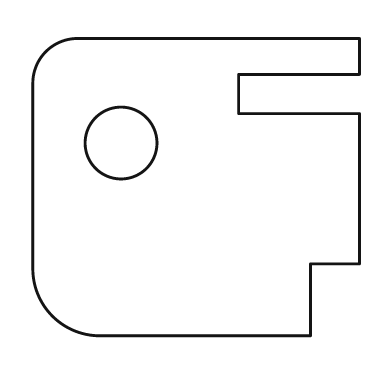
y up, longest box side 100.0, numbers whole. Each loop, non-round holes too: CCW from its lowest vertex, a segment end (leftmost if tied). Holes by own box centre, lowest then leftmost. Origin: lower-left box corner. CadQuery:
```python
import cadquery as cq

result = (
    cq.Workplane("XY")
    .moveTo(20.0, 0.0)
    .lineTo(85.0, 0.0)
    .lineTo(85.0, 22.0)
    .lineTo(100.0, 22.0)
    .lineTo(100.0, 68.0)
    .lineTo(63.0, 68.0)
    .lineTo(63.0, 80.0)
    .lineTo(100.0, 80.0)
    .lineTo(100.0, 91.0)
    .lineTo(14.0, 91.0)
    .threePointArc((4.0, 87.0), (0.0, 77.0))
    .lineTo(0.0, 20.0)
    .threePointArc((6.0, 6.0), (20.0, 0.0))
    .close()
    .moveTo(27.0, 59.0)
    .circle(11.0)
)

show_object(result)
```